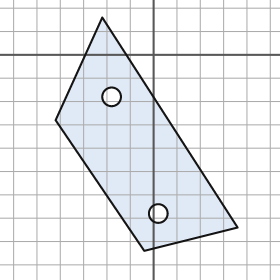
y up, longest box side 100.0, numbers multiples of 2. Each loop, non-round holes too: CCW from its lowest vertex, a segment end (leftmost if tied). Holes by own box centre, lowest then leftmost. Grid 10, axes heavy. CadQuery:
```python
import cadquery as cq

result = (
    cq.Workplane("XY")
    .moveTo(-4.0, -84.0)
    .lineTo(36.0, -74.0)
    .lineTo(-22.0, 16.0)
    .lineTo(-42.0, -28.0)
    .close()
    .moveTo(2.0, -68.0)
    .circle(4.0)
    .moveTo(-18.0, -18.0)
    .circle(4.0)
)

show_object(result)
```